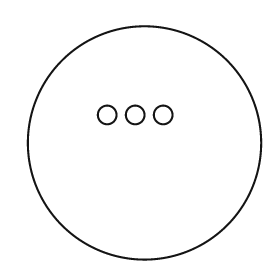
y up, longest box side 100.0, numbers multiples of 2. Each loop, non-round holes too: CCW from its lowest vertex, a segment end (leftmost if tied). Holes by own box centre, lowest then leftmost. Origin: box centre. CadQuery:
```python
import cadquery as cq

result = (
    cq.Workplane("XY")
    .moveTo(0.0, 0.0)
    .circle(50.0)
    .moveTo(-16.0, 12.0)
    .circle(4.0)
    .moveTo(-4.0, 12.0)
    .circle(4.0)
    .moveTo(8.0, 12.0)
    .circle(4.0)
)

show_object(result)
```